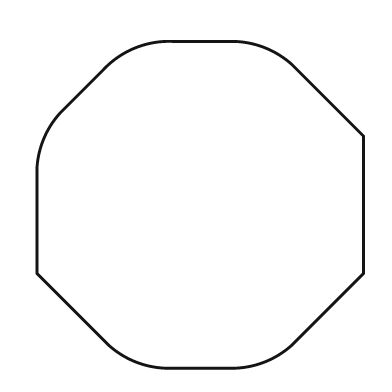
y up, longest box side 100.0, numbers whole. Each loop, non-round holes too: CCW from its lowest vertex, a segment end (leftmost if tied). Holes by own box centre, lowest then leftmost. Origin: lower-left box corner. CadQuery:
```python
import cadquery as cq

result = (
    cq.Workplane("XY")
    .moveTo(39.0, 0.0)
    .lineTo(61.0, 0.0)
    .threePointArc((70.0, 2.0), (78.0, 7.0))
    .lineTo(100.0, 29.0)
    .lineTo(100.0, 71.0)
    .lineTo(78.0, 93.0)
    .threePointArc((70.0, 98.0), (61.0, 100.0))
    .lineTo(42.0, 100.0)
    .threePointArc((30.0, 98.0), (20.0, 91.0))
    .lineTo(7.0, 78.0)
    .threePointArc((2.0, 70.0), (0.0, 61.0))
    .lineTo(0.0, 29.0)
    .lineTo(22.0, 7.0)
    .threePointArc((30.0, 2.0), (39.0, 0.0))
    .close()
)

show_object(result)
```